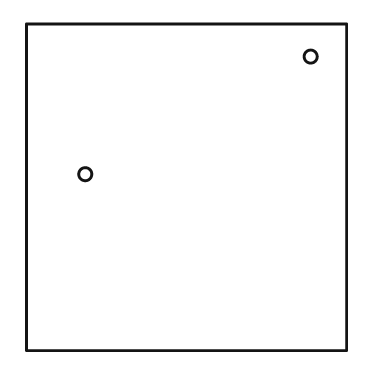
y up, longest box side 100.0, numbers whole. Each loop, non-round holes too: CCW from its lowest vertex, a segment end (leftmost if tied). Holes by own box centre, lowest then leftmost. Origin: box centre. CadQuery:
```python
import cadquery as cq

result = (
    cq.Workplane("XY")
    .moveTo(-49.0, -50.0)
    .lineTo(49.0, -50.0)
    .lineTo(49.0, 50.0)
    .lineTo(-49.0, 50.0)
    .close()
    .moveTo(-31.0, 4.0)
    .circle(2.0)
    .moveTo(38.0, 40.0)
    .circle(2.0)
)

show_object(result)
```